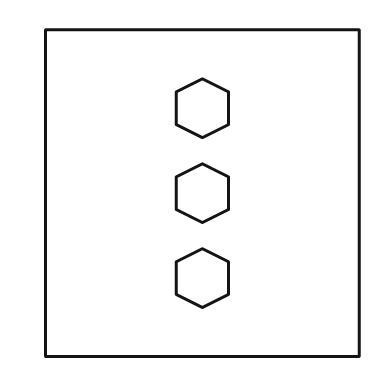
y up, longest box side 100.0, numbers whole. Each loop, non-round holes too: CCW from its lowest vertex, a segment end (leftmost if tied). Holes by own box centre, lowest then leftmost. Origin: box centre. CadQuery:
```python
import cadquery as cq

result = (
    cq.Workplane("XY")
    .moveTo(-48.0, -50.0)
    .lineTo(48.0, -50.0)
    .lineTo(48.0, 50.0)
    .lineTo(-48.0, 50.0)
    .close()
    .moveTo(0.0, -35.0)
    .lineTo(8.0, -31.0)
    .lineTo(8.0, -21.0)
    .lineTo(0.0, -17.0)
    .lineTo(-8.0, -21.0)
    .lineTo(-8.0, -31.0)
    .close()
    .moveTo(0.0, -9.0)
    .lineTo(8.0, -5.0)
    .lineTo(8.0, 5.0)
    .lineTo(0.0, 9.0)
    .lineTo(-8.0, 5.0)
    .lineTo(-8.0, -5.0)
    .close()
    .moveTo(0.0, 17.0)
    .lineTo(8.0, 21.0)
    .lineTo(8.0, 31.0)
    .lineTo(0.0, 35.0)
    .lineTo(-8.0, 31.0)
    .lineTo(-8.0, 21.0)
    .close()
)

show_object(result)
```